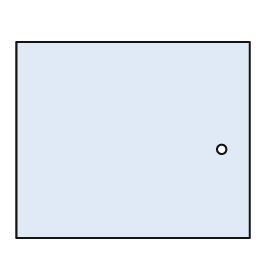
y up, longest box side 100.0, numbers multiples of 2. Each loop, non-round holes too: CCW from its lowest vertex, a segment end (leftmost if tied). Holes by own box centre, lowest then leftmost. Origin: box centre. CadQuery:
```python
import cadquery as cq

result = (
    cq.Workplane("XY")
    .moveTo(-50.0, -42.0)
    .lineTo(50.0, -42.0)
    .lineTo(50.0, 42.0)
    .lineTo(-50.0, 42.0)
    .close()
    .moveTo(38.0, -4.0)
    .circle(2.0)
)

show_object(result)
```